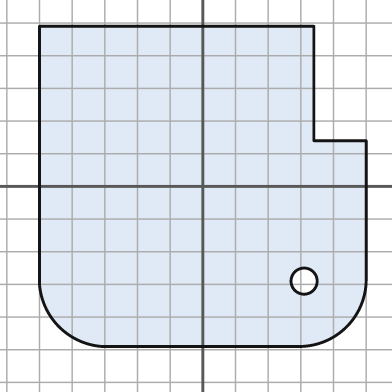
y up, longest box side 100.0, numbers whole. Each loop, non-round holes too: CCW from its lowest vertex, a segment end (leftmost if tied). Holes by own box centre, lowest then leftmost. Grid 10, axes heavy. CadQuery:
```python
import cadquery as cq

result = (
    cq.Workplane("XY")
    .moveTo(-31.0, -49.0)
    .lineTo(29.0, -49.0)
    .threePointArc((44.0, -43.0), (50.0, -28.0))
    .lineTo(50.0, 14.0)
    .lineTo(34.0, 14.0)
    .lineTo(34.0, 49.0)
    .lineTo(-50.0, 49.0)
    .lineTo(-50.0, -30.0)
    .threePointArc((-44.0, -43.0), (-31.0, -49.0))
    .close()
    .moveTo(31.0, -29.0)
    .circle(4.0)
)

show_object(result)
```